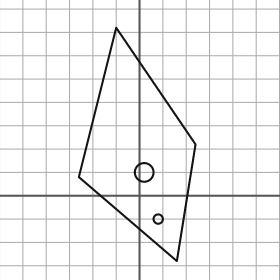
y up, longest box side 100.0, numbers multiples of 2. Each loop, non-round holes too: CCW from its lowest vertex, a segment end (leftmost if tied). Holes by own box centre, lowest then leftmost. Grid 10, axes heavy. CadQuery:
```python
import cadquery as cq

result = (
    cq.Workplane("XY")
    .moveTo(16.0, -28.0)
    .lineTo(24.0, 22.0)
    .lineTo(-10.0, 72.0)
    .lineTo(-26.0, 8.0)
    .close()
    .moveTo(8.0, -10.0)
    .circle(2.0)
    .moveTo(2.0, 10.0)
    .circle(4.0)
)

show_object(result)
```